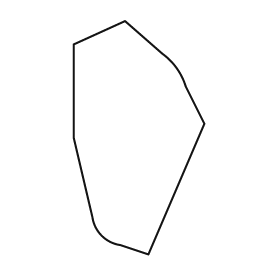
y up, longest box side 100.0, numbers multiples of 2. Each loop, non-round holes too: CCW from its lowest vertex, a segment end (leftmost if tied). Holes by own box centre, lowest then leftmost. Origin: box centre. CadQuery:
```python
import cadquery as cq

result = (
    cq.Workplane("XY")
    .moveTo(4.0, -50.0)
    .lineTo(28.0, 6.0)
    .lineTo(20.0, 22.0)
    .threePointArc((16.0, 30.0), (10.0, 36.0))
    .lineTo(-6.0, 50.0)
    .lineTo(-28.0, 40.0)
    .lineTo(-28.0, 0.0)
    .lineTo(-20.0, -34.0)
    .threePointArc((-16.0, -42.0), (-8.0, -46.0))
    .close()
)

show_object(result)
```